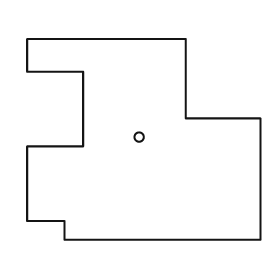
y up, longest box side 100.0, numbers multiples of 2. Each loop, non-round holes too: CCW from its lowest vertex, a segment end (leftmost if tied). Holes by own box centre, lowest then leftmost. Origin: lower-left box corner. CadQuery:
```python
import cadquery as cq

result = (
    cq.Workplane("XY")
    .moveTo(16.0, 0.0)
    .lineTo(100.0, 0.0)
    .lineTo(100.0, 52.0)
    .lineTo(68.0, 52.0)
    .lineTo(68.0, 86.0)
    .lineTo(0.0, 86.0)
    .lineTo(0.0, 72.0)
    .lineTo(24.0, 72.0)
    .lineTo(24.0, 40.0)
    .lineTo(0.0, 40.0)
    .lineTo(0.0, 8.0)
    .lineTo(16.0, 8.0)
    .close()
    .moveTo(48.0, 44.0)
    .circle(2.0)
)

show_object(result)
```